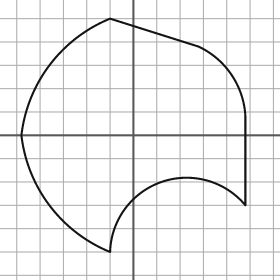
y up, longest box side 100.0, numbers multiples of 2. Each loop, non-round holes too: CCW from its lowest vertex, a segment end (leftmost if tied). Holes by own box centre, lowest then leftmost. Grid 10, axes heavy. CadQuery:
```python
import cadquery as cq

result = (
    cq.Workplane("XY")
    .moveTo(-10.0, -50.0)
    .threePointArc((12.0, -20.0), (48.0, -30.0))
    .lineTo(48.0, 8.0)
    .threePointArc((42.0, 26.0), (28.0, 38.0))
    .lineTo(-10.0, 50.0)
    .threePointArc((-36.0, 30.0), (-48.0, 0.0))
    .threePointArc((-36.0, -30.0), (-10.0, -50.0))
    .close()
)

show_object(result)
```